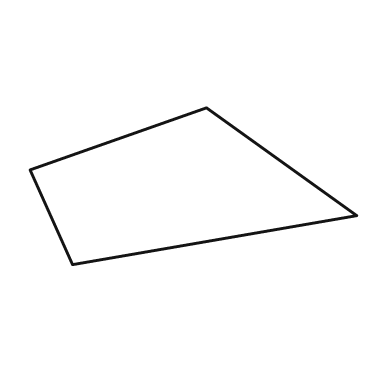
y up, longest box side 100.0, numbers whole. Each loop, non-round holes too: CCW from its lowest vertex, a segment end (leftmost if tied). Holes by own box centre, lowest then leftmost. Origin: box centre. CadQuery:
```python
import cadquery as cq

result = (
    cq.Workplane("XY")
    .moveTo(-37.0, -24.0)
    .lineTo(50.0, -9.0)
    .lineTo(4.0, 24.0)
    .lineTo(-50.0, 5.0)
    .close()
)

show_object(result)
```